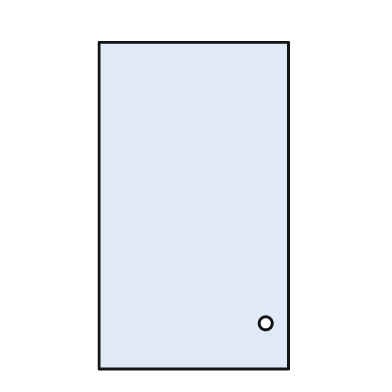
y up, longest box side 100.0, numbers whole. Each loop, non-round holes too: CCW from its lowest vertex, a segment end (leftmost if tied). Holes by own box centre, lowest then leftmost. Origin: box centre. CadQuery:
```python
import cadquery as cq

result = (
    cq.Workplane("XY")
    .moveTo(-29.0, -50.0)
    .lineTo(29.0, -50.0)
    .lineTo(29.0, 50.0)
    .lineTo(-29.0, 50.0)
    .close()
    .moveTo(22.0, -36.0)
    .circle(2.0)
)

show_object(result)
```